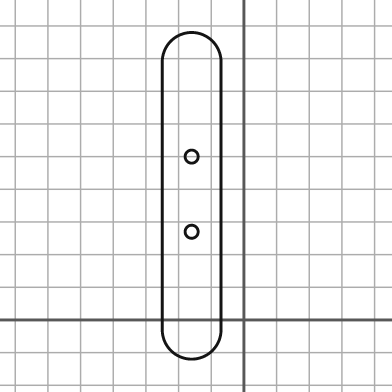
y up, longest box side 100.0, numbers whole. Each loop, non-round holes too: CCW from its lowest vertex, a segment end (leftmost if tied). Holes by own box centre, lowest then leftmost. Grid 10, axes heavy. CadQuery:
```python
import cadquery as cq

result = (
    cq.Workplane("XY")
    .moveTo(-25.0, -3.0)
    .threePointArc((-16.0, -12.0), (-7.0, -3.0))
    .lineTo(-7.0, 79.0)
    .threePointArc((-16.0, 88.0), (-25.0, 79.0))
    .close()
    .moveTo(-16.0, 27.0)
    .circle(2.0)
    .moveTo(-16.0, 50.0)
    .circle(2.0)
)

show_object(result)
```